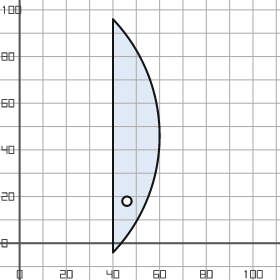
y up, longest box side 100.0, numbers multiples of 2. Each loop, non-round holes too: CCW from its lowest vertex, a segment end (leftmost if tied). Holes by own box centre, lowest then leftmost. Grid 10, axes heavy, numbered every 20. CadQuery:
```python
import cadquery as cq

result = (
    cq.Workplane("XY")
    .moveTo(40.0, -4.0)
    .threePointArc((60.0, 46.0), (40.0, 96.0))
    .close()
    .moveTo(46.0, 18.0)
    .circle(2.0)
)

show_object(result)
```